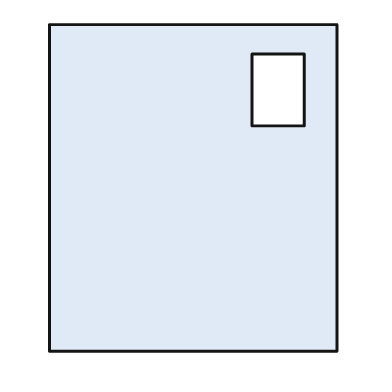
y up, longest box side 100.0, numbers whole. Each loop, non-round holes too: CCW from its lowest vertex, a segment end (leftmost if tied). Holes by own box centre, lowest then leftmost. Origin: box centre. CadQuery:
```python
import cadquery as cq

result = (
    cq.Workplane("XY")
    .moveTo(-44.0, -50.0)
    .lineTo(44.0, -50.0)
    .lineTo(44.0, 50.0)
    .lineTo(-44.0, 50.0)
    .close()
    .moveTo(18.0, 19.0)
    .lineTo(34.0, 19.0)
    .lineTo(34.0, 41.0)
    .lineTo(18.0, 41.0)
    .close()
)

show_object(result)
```